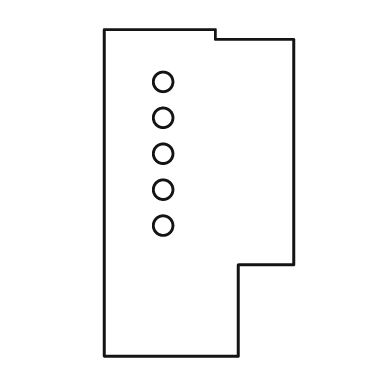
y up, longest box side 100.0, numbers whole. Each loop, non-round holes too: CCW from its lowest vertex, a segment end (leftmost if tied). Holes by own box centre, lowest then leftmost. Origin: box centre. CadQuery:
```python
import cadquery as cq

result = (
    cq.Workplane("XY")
    .moveTo(-29.0, -50.0)
    .lineTo(12.0, -50.0)
    .lineTo(12.0, -22.0)
    .lineTo(29.0, -22.0)
    .lineTo(29.0, 47.0)
    .lineTo(5.0, 47.0)
    .lineTo(5.0, 50.0)
    .lineTo(-29.0, 50.0)
    .close()
    .moveTo(-11.0, -10.0)
    .circle(3.0)
    .moveTo(-11.0, 1.0)
    .circle(3.0)
    .moveTo(-11.0, 12.0)
    .circle(3.0)
    .moveTo(-11.0, 23.0)
    .circle(3.0)
    .moveTo(-11.0, 34.0)
    .circle(3.0)
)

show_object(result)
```